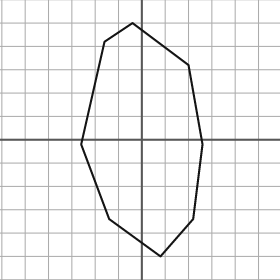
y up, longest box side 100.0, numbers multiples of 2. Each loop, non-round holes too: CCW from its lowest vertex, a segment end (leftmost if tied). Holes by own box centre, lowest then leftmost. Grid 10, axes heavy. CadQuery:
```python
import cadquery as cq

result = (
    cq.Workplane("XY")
    .moveTo(8.0, -50.0)
    .lineTo(22.0, -34.0)
    .lineTo(26.0, -2.0)
    .lineTo(20.0, 32.0)
    .lineTo(-4.0, 50.0)
    .lineTo(-16.0, 42.0)
    .lineTo(-26.0, -2.0)
    .lineTo(-14.0, -34.0)
    .close()
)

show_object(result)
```